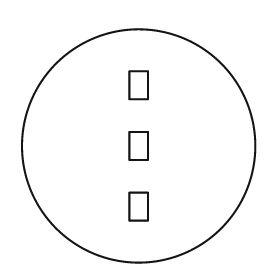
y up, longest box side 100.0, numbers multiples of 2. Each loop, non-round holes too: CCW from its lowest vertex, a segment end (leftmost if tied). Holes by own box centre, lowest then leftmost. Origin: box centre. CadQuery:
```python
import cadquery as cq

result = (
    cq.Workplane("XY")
    .moveTo(0.0, 0.0)
    .circle(50.0)
    .moveTo(-4.0, -32.0)
    .lineTo(4.0, -32.0)
    .lineTo(4.0, -20.0)
    .lineTo(-4.0, -20.0)
    .close()
    .moveTo(-4.0, -6.0)
    .lineTo(4.0, -6.0)
    .lineTo(4.0, 6.0)
    .lineTo(-4.0, 6.0)
    .close()
    .moveTo(-4.0, 20.0)
    .lineTo(4.0, 20.0)
    .lineTo(4.0, 32.0)
    .lineTo(-4.0, 32.0)
    .close()
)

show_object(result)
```